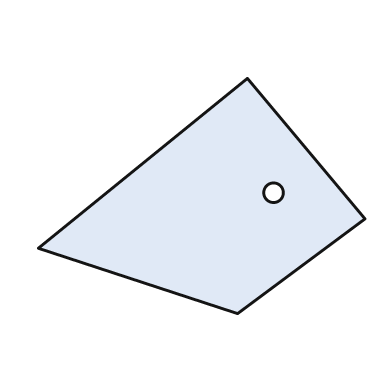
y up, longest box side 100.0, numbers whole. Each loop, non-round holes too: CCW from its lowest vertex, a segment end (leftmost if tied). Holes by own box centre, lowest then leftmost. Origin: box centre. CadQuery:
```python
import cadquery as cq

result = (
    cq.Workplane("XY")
    .moveTo(11.0, -36.0)
    .lineTo(50.0, -7.0)
    .lineTo(14.0, 36.0)
    .lineTo(-50.0, -16.0)
    .close()
    .moveTo(22.0, 1.0)
    .circle(3.0)
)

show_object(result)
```